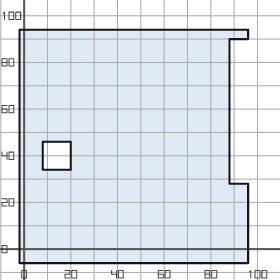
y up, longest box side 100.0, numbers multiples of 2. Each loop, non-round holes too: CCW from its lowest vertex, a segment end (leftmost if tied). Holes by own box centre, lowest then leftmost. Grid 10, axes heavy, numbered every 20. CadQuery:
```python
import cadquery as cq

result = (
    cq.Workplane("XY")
    .moveTo(-2.0, -6.0)
    .lineTo(96.0, -6.0)
    .lineTo(96.0, 28.0)
    .lineTo(88.0, 28.0)
    .lineTo(88.0, 90.0)
    .lineTo(96.0, 90.0)
    .lineTo(96.0, 94.0)
    .lineTo(-2.0, 94.0)
    .close()
    .moveTo(8.0, 34.0)
    .lineTo(20.0, 34.0)
    .lineTo(20.0, 46.0)
    .lineTo(8.0, 46.0)
    .close()
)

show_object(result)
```